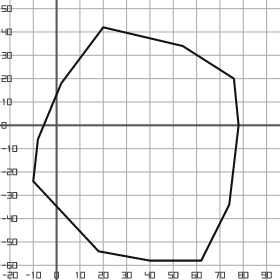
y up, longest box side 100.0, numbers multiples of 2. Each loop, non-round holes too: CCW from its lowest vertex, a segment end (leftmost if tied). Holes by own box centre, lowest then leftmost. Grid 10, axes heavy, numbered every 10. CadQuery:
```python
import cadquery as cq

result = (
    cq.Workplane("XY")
    .moveTo(40.0, -58.0)
    .lineTo(62.0, -58.0)
    .lineTo(74.0, -34.0)
    .lineTo(78.0, 0.0)
    .lineTo(76.0, 20.0)
    .lineTo(54.0, 34.0)
    .lineTo(20.0, 42.0)
    .lineTo(2.0, 18.0)
    .lineTo(-8.0, -6.0)
    .lineTo(-10.0, -24.0)
    .lineTo(18.0, -54.0)
    .close()
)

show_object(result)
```